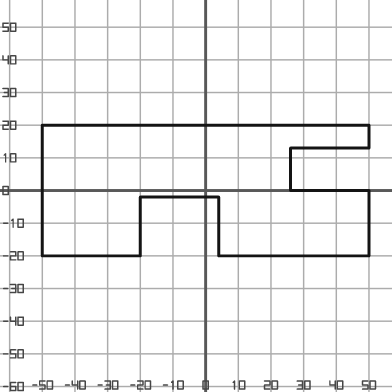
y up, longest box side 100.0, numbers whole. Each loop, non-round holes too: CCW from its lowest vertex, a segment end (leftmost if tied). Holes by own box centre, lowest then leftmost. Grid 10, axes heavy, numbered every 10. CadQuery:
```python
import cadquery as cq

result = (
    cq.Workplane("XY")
    .moveTo(-50.0, -20.0)
    .lineTo(-20.0, -20.0)
    .lineTo(-20.0, -2.0)
    .lineTo(4.0, -2.0)
    .lineTo(4.0, -20.0)
    .lineTo(50.0, -20.0)
    .lineTo(50.0, 0.0)
    .lineTo(26.0, 0.0)
    .lineTo(26.0, 13.0)
    .lineTo(50.0, 13.0)
    .lineTo(50.0, 20.0)
    .lineTo(-50.0, 20.0)
    .close()
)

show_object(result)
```